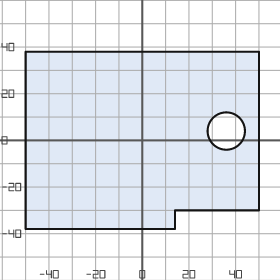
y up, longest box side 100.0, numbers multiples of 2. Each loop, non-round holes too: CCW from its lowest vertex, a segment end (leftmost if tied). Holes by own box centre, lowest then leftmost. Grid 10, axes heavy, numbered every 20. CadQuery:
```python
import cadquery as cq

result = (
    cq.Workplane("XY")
    .moveTo(-50.0, -38.0)
    .lineTo(14.0, -38.0)
    .lineTo(14.0, -30.0)
    .lineTo(50.0, -30.0)
    .lineTo(50.0, 38.0)
    .lineTo(-50.0, 38.0)
    .close()
    .moveTo(36.0, 4.0)
    .circle(8.0)
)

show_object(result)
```